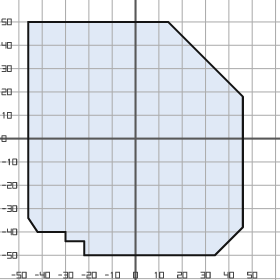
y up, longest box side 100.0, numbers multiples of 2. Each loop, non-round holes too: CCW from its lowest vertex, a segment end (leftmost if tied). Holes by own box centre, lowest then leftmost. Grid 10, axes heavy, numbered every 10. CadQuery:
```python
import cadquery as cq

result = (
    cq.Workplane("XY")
    .moveTo(-22.0, -50.0)
    .lineTo(34.0, -50.0)
    .lineTo(46.0, -38.0)
    .lineTo(46.0, 18.0)
    .lineTo(14.0, 50.0)
    .lineTo(-46.0, 50.0)
    .lineTo(-46.0, -34.0)
    .lineTo(-42.0, -40.0)
    .lineTo(-30.0, -40.0)
    .lineTo(-30.0, -44.0)
    .lineTo(-22.0, -44.0)
    .close()
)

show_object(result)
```